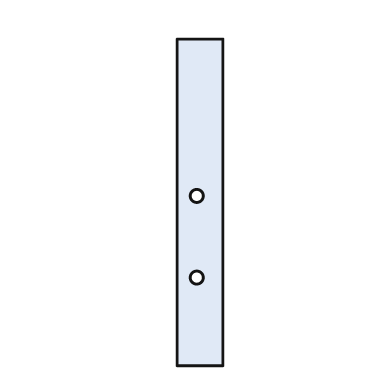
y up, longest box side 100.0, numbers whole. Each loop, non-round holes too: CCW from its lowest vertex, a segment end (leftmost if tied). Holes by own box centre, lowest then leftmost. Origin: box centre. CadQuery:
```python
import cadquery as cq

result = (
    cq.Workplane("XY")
    .moveTo(-7.0, -50.0)
    .lineTo(7.0, -50.0)
    .lineTo(7.0, 50.0)
    .lineTo(-7.0, 50.0)
    .close()
    .moveTo(-1.0, -23.0)
    .circle(2.0)
    .moveTo(-1.0, 2.0)
    .circle(2.0)
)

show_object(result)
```